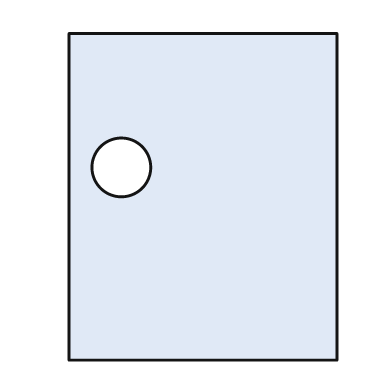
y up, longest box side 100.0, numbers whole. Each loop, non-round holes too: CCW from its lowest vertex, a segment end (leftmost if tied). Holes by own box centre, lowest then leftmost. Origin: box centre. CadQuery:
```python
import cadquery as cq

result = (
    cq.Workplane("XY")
    .moveTo(-41.0, -50.0)
    .lineTo(41.0, -50.0)
    .lineTo(41.0, 50.0)
    .lineTo(-41.0, 50.0)
    .close()
    .moveTo(-25.0, 9.0)
    .circle(9.0)
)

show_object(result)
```